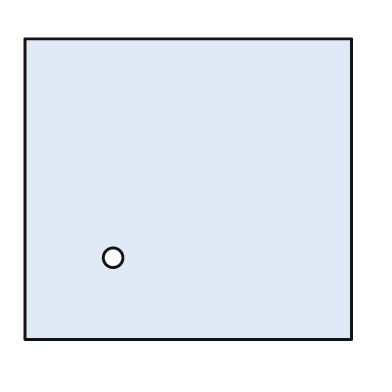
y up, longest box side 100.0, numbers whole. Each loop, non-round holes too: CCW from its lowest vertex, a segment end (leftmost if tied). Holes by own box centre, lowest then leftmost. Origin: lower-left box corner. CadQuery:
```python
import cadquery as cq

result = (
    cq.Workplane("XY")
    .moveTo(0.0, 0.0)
    .lineTo(100.0, 0.0)
    .lineTo(100.0, 92.0)
    .lineTo(0.0, 92.0)
    .close()
    .moveTo(27.0, 25.0)
    .circle(3.0)
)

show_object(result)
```